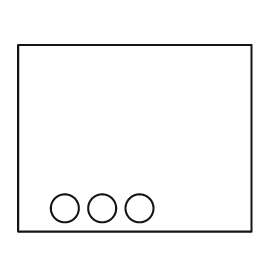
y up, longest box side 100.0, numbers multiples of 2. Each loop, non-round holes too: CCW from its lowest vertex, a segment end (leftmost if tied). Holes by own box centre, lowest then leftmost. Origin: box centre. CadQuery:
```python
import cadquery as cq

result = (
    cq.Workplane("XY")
    .moveTo(-50.0, -40.0)
    .lineTo(50.0, -40.0)
    .lineTo(50.0, 40.0)
    .lineTo(-50.0, 40.0)
    .close()
    .moveTo(-30.0, -30.0)
    .circle(6.0)
    .moveTo(-14.0, -30.0)
    .circle(6.0)
    .moveTo(2.0, -30.0)
    .circle(6.0)
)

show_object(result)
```